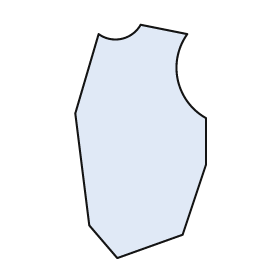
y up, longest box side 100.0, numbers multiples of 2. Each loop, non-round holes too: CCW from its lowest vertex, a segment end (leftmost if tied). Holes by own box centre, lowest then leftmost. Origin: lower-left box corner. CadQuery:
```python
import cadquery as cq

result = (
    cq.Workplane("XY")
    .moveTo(18.0, 0.0)
    .lineTo(46.0, 10.0)
    .lineTo(56.0, 40.0)
    .lineTo(56.0, 60.0)
    .threePointArc((44.0, 76.0), (48.0, 96.0))
    .lineTo(28.0, 100.0)
    .threePointArc((20.0, 94.0), (10.0, 96.0))
    .lineTo(0.0, 62.0)
    .lineTo(6.0, 14.0)
    .close()
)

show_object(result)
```